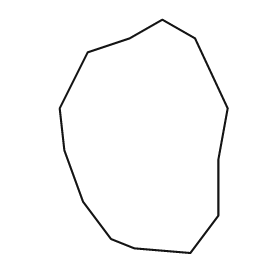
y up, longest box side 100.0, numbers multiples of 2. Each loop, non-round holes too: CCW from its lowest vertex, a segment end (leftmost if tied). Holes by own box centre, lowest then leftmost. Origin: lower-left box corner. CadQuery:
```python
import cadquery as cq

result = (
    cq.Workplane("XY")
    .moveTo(56.0, 0.0)
    .lineTo(68.0, 16.0)
    .lineTo(68.0, 40.0)
    .lineTo(72.0, 62.0)
    .lineTo(58.0, 92.0)
    .lineTo(44.0, 100.0)
    .lineTo(30.0, 92.0)
    .lineTo(12.0, 86.0)
    .lineTo(0.0, 62.0)
    .lineTo(2.0, 44.0)
    .lineTo(10.0, 22.0)
    .lineTo(22.0, 6.0)
    .lineTo(32.0, 2.0)
    .close()
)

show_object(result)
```